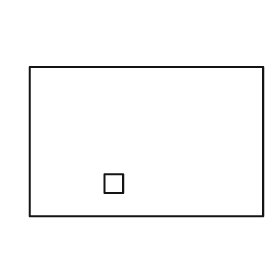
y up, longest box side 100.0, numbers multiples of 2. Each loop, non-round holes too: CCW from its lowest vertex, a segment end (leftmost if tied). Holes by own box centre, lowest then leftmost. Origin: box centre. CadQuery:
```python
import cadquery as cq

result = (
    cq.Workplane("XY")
    .moveTo(-50.0, -32.0)
    .lineTo(50.0, -32.0)
    .lineTo(50.0, 32.0)
    .lineTo(-50.0, 32.0)
    .close()
    .moveTo(-18.0, -22.0)
    .lineTo(-10.0, -22.0)
    .lineTo(-10.0, -14.0)
    .lineTo(-18.0, -14.0)
    .close()
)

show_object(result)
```